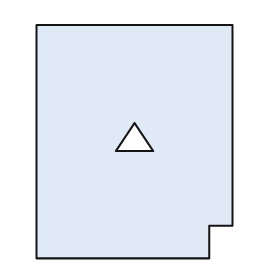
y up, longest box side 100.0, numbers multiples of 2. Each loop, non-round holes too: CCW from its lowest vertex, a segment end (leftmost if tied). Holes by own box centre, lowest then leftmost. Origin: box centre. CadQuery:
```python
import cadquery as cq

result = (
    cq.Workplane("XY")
    .moveTo(-42.0, -50.0)
    .lineTo(32.0, -50.0)
    .lineTo(32.0, -36.0)
    .lineTo(42.0, -36.0)
    .lineTo(42.0, 50.0)
    .lineTo(-42.0, 50.0)
    .close()
    .moveTo(-8.0, -4.0)
    .lineTo(8.0, -4.0)
    .lineTo(0.0, 8.0)
    .close()
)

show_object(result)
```